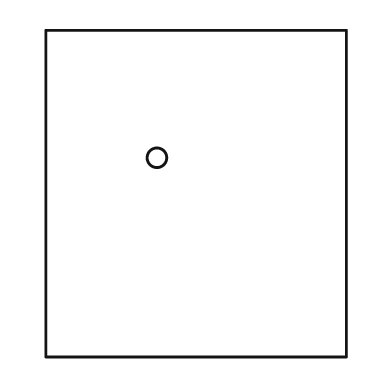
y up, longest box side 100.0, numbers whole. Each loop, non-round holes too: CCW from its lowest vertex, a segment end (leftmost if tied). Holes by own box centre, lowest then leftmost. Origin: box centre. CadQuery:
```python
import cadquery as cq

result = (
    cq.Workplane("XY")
    .moveTo(-46.0, -50.0)
    .lineTo(46.0, -50.0)
    .lineTo(46.0, 50.0)
    .lineTo(-46.0, 50.0)
    .close()
    .moveTo(-12.0, 11.0)
    .circle(3.0)
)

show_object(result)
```